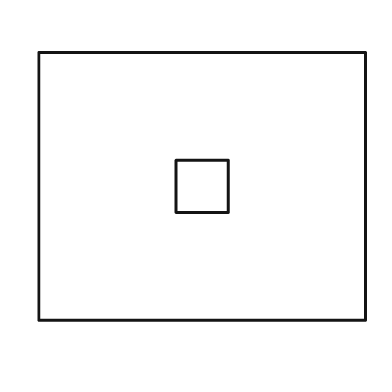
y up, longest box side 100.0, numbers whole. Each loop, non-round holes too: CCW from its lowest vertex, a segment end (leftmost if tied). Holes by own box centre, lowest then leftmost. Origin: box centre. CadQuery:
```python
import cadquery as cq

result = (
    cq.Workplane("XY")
    .moveTo(-50.0, -41.0)
    .lineTo(50.0, -41.0)
    .lineTo(50.0, 41.0)
    .lineTo(-50.0, 41.0)
    .close()
    .moveTo(-8.0, -8.0)
    .lineTo(8.0, -8.0)
    .lineTo(8.0, 8.0)
    .lineTo(-8.0, 8.0)
    .close()
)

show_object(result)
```